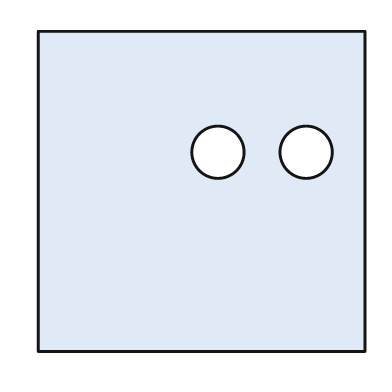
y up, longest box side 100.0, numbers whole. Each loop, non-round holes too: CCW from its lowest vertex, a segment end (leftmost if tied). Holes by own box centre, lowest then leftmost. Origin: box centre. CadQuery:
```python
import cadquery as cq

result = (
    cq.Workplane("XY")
    .moveTo(-50.0, -49.0)
    .lineTo(50.0, -49.0)
    .lineTo(50.0, 49.0)
    .lineTo(-50.0, 49.0)
    .close()
    .moveTo(5.0, 12.0)
    .circle(8.0)
    .moveTo(32.0, 12.0)
    .circle(8.0)
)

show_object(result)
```